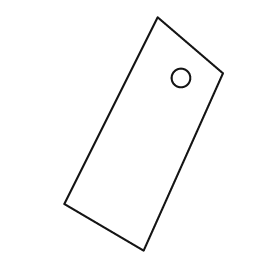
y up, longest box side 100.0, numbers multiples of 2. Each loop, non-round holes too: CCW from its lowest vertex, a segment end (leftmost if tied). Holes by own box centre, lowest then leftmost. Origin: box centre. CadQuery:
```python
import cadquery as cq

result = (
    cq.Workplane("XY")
    .moveTo(0.0, -50.0)
    .lineTo(34.0, 26.0)
    .lineTo(6.0, 50.0)
    .lineTo(-34.0, -30.0)
    .close()
    .moveTo(16.0, 24.0)
    .circle(4.0)
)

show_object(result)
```